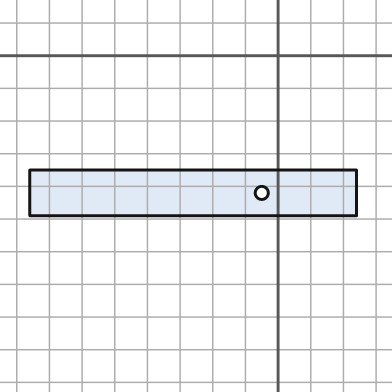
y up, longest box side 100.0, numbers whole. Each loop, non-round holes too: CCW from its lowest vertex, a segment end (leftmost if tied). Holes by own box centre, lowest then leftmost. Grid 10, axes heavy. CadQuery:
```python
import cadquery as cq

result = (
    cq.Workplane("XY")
    .moveTo(-76.0, -49.0)
    .lineTo(24.0, -49.0)
    .lineTo(24.0, -35.0)
    .lineTo(-76.0, -35.0)
    .close()
    .moveTo(-5.0, -42.0)
    .circle(2.0)
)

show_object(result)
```